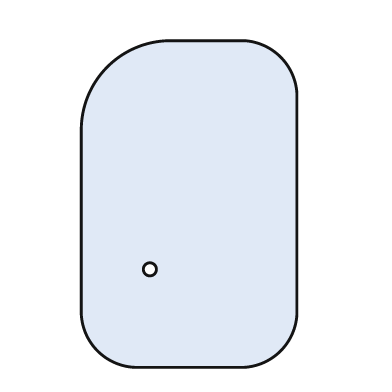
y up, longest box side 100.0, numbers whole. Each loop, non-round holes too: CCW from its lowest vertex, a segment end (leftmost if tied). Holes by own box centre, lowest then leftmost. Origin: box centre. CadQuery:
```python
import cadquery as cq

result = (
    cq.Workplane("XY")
    .moveTo(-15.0, -50.0)
    .lineTo(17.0, -50.0)
    .threePointArc((28.0, -45.0), (33.0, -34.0))
    .lineTo(33.0, 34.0)
    .threePointArc((28.0, 45.0), (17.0, 50.0))
    .lineTo(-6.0, 50.0)
    .threePointArc((-25.0, 42.0), (-33.0, 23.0))
    .lineTo(-33.0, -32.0)
    .threePointArc((-28.0, -45.0), (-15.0, -50.0))
    .close()
    .moveTo(-12.0, -20.0)
    .circle(2.0)
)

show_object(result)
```